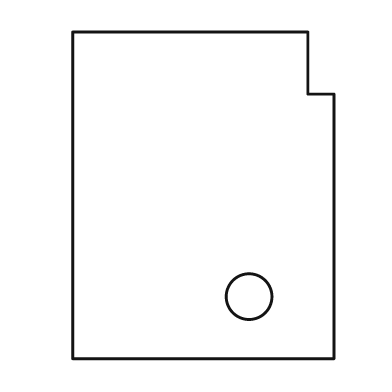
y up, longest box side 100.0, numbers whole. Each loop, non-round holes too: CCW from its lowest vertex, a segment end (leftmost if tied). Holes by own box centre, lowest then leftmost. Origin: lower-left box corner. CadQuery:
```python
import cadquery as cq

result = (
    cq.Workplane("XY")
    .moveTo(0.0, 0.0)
    .lineTo(80.0, 0.0)
    .lineTo(80.0, 81.0)
    .lineTo(72.0, 81.0)
    .lineTo(72.0, 100.0)
    .lineTo(0.0, 100.0)
    .close()
    .moveTo(54.0, 19.0)
    .circle(7.0)
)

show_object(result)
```